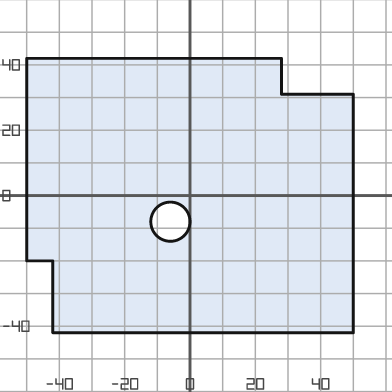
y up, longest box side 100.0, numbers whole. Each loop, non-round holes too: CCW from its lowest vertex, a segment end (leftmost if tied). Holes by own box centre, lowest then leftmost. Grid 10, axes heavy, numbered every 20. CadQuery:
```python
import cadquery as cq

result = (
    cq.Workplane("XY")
    .moveTo(-42.0, -42.0)
    .lineTo(50.0, -42.0)
    .lineTo(50.0, 31.0)
    .lineTo(28.0, 31.0)
    .lineTo(28.0, 42.0)
    .lineTo(-50.0, 42.0)
    .lineTo(-50.0, -20.0)
    .lineTo(-42.0, -20.0)
    .close()
    .moveTo(-6.0, -8.0)
    .circle(6.0)
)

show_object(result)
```